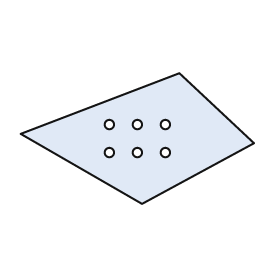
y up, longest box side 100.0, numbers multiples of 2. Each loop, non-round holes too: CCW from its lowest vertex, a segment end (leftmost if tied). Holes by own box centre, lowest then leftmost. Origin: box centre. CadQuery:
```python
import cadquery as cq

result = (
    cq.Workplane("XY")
    .moveTo(2.0, -28.0)
    .lineTo(50.0, -2.0)
    .lineTo(18.0, 28.0)
    .lineTo(-50.0, 2.0)
    .close()
    .moveTo(-12.0, -6.0)
    .circle(2.0)
    .moveTo(0.0, -6.0)
    .circle(2.0)
    .moveTo(12.0, -6.0)
    .circle(2.0)
    .moveTo(-12.0, 6.0)
    .circle(2.0)
    .moveTo(0.0, 6.0)
    .circle(2.0)
    .moveTo(12.0, 6.0)
    .circle(2.0)
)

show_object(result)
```